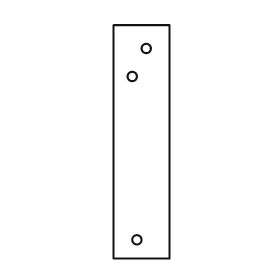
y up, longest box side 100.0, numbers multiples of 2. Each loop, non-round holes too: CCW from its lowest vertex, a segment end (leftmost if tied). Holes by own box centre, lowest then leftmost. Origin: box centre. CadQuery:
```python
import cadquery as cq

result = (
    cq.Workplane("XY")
    .moveTo(-12.0, -50.0)
    .lineTo(12.0, -50.0)
    .lineTo(12.0, 50.0)
    .lineTo(-12.0, 50.0)
    .close()
    .moveTo(-2.0, -42.0)
    .circle(2.0)
    .moveTo(-4.0, 28.0)
    .circle(2.0)
    .moveTo(2.0, 40.0)
    .circle(2.0)
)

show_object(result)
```